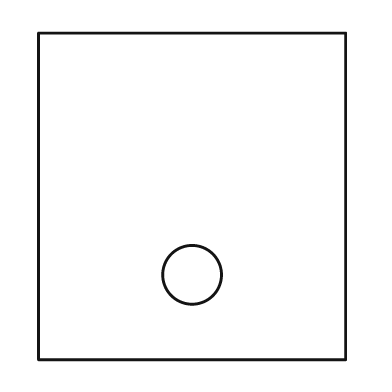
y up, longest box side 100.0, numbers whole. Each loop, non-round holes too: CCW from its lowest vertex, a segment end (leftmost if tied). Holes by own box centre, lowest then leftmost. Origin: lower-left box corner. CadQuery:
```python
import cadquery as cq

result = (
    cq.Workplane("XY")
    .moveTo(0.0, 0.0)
    .lineTo(94.0, 0.0)
    .lineTo(94.0, 100.0)
    .lineTo(0.0, 100.0)
    .close()
    .moveTo(47.0, 26.0)
    .circle(9.0)
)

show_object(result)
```